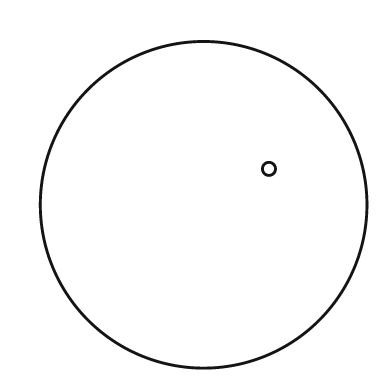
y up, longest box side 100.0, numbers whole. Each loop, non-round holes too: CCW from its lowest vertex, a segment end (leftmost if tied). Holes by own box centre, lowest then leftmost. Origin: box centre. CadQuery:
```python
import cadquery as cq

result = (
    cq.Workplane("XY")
    .moveTo(0.0, 0.0)
    .circle(50.0)
    .moveTo(20.0, 11.0)
    .circle(2.0)
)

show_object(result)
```